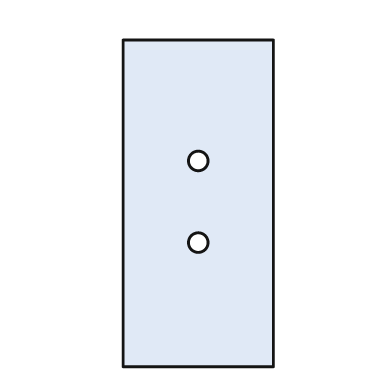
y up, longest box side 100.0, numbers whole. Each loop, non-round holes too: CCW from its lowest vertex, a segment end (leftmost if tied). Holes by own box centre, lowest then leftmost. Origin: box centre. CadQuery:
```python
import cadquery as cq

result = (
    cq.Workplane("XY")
    .moveTo(-23.0, -50.0)
    .lineTo(23.0, -50.0)
    .lineTo(23.0, 50.0)
    .lineTo(-23.0, 50.0)
    .close()
    .moveTo(0.0, -12.0)
    .circle(3.0)
    .moveTo(0.0, 13.0)
    .circle(3.0)
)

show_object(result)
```